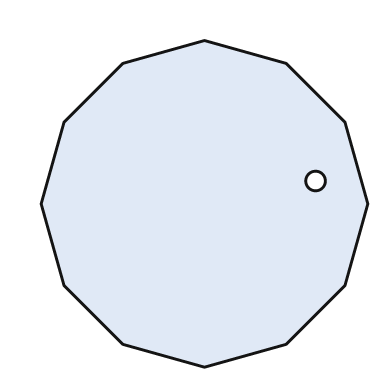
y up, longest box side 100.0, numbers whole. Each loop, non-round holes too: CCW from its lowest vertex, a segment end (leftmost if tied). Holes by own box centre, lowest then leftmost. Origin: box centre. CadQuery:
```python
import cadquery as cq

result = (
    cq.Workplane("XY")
    .moveTo(0.0, -50.0)
    .lineTo(25.0, -43.0)
    .lineTo(43.0, -25.0)
    .lineTo(50.0, 0.0)
    .lineTo(43.0, 25.0)
    .lineTo(25.0, 43.0)
    .lineTo(0.0, 50.0)
    .lineTo(-25.0, 43.0)
    .lineTo(-43.0, 25.0)
    .lineTo(-50.0, 0.0)
    .lineTo(-43.0, -25.0)
    .lineTo(-25.0, -43.0)
    .close()
    .moveTo(34.0, 7.0)
    .circle(3.0)
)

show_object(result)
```